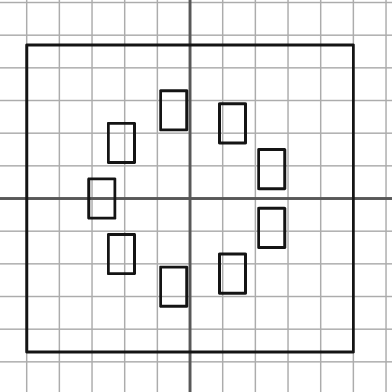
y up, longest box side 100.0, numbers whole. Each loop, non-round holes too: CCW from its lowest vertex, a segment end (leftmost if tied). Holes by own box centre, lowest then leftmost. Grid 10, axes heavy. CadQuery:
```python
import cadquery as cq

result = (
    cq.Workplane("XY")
    .moveTo(-50.0, -47.0)
    .lineTo(50.0, -47.0)
    .lineTo(50.0, 47.0)
    .lineTo(-50.0, 47.0)
    .close()
    .moveTo(-9.0, -33.0)
    .lineTo(-1.0, -33.0)
    .lineTo(-1.0, -21.0)
    .lineTo(-9.0, -21.0)
    .close()
    .moveTo(9.0, -29.0)
    .lineTo(17.0, -29.0)
    .lineTo(17.0, -17.0)
    .lineTo(9.0, -17.0)
    .close()
    .moveTo(-25.0, -23.0)
    .lineTo(-17.0, -23.0)
    .lineTo(-17.0, -11.0)
    .lineTo(-25.0, -11.0)
    .close()
    .moveTo(21.0, -15.0)
    .lineTo(29.0, -15.0)
    .lineTo(29.0, -3.0)
    .lineTo(21.0, -3.0)
    .close()
    .moveTo(-31.0, -6.0)
    .lineTo(-23.0, -6.0)
    .lineTo(-23.0, 6.0)
    .lineTo(-31.0, 6.0)
    .close()
    .moveTo(21.0, 3.0)
    .lineTo(29.0, 3.0)
    .lineTo(29.0, 15.0)
    .lineTo(21.0, 15.0)
    .close()
    .moveTo(-25.0, 11.0)
    .lineTo(-17.0, 11.0)
    .lineTo(-17.0, 23.0)
    .lineTo(-25.0, 23.0)
    .close()
    .moveTo(9.0, 17.0)
    .lineTo(17.0, 17.0)
    .lineTo(17.0, 29.0)
    .lineTo(9.0, 29.0)
    .close()
    .moveTo(-9.0, 21.0)
    .lineTo(-1.0, 21.0)
    .lineTo(-1.0, 33.0)
    .lineTo(-9.0, 33.0)
    .close()
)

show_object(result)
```